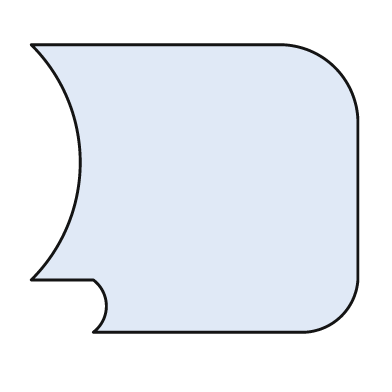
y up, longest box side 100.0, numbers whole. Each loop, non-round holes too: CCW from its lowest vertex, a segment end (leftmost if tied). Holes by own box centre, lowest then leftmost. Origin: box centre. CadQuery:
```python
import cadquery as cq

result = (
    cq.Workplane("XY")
    .moveTo(-31.0, -44.0)
    .lineTo(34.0, -44.0)
    .threePointArc((45.0, -39.0), (50.0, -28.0))
    .lineTo(50.0, 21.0)
    .threePointArc((43.0, 37.0), (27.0, 44.0))
    .lineTo(-50.0, 44.0)
    .threePointArc((-35.0, 8.0), (-50.0, -28.0))
    .lineTo(-31.0, -28.0)
    .threePointArc((-27.0, -36.0), (-31.0, -44.0))
    .close()
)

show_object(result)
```